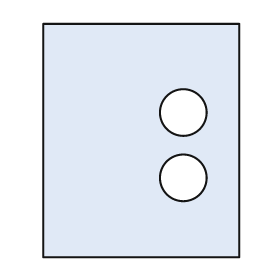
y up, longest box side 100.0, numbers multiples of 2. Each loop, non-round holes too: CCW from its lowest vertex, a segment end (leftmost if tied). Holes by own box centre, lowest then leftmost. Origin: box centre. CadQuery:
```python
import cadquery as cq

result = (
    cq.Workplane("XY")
    .moveTo(-42.0, -50.0)
    .lineTo(42.0, -50.0)
    .lineTo(42.0, 50.0)
    .lineTo(-42.0, 50.0)
    .close()
    .moveTo(18.0, -16.0)
    .circle(10.0)
    .moveTo(18.0, 12.0)
    .circle(10.0)
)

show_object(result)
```